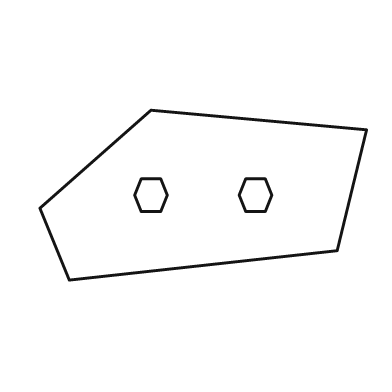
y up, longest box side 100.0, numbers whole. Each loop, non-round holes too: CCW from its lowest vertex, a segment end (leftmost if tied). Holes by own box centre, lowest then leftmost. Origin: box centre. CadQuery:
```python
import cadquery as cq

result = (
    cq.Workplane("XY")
    .moveTo(-41.0, -26.0)
    .lineTo(41.0, -17.0)
    .lineTo(50.0, 20.0)
    .lineTo(-16.0, 26.0)
    .lineTo(-50.0, -4.0)
    .close()
    .moveTo(-19.0, -5.0)
    .lineTo(-13.0, -5.0)
    .lineTo(-11.0, 0.0)
    .lineTo(-13.0, 5.0)
    .lineTo(-19.0, 5.0)
    .lineTo(-21.0, 0.0)
    .close()
    .moveTo(13.0, -5.0)
    .lineTo(19.0, -5.0)
    .lineTo(21.0, 0.0)
    .lineTo(19.0, 5.0)
    .lineTo(13.0, 5.0)
    .lineTo(11.0, 0.0)
    .close()
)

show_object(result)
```